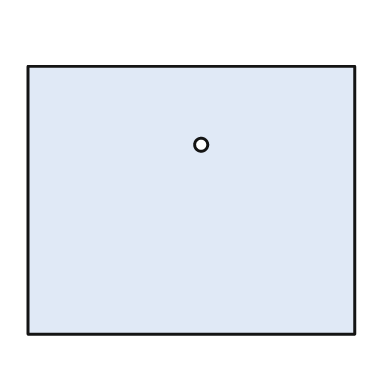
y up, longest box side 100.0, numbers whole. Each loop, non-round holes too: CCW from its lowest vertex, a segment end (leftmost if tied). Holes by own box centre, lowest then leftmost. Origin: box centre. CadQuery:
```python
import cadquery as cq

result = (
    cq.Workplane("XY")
    .moveTo(-50.0, -41.0)
    .lineTo(50.0, -41.0)
    .lineTo(50.0, 41.0)
    .lineTo(-50.0, 41.0)
    .close()
    .moveTo(3.0, 17.0)
    .circle(2.0)
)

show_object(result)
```